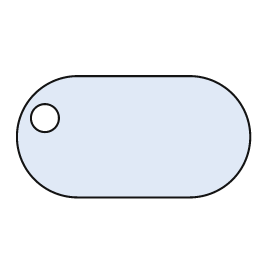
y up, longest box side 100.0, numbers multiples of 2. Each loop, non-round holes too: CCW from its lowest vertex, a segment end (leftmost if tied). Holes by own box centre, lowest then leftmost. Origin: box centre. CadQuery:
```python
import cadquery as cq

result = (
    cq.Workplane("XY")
    .moveTo(-24.0, -26.0)
    .lineTo(24.0, -26.0)
    .threePointArc((50.0, 0.0), (24.0, 26.0))
    .lineTo(-24.0, 26.0)
    .threePointArc((-50.0, 0.0), (-24.0, -26.0))
    .close()
    .moveTo(-38.0, 8.0)
    .circle(6.0)
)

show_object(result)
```